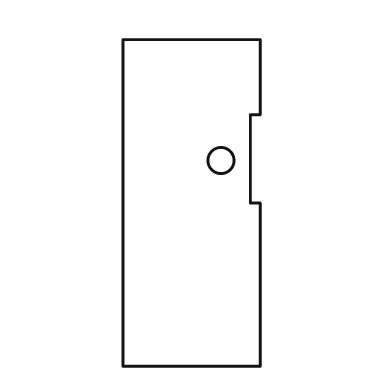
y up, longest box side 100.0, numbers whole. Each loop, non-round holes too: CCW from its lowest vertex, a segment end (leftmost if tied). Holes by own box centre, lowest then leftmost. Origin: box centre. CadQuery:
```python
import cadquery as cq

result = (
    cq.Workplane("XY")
    .moveTo(-21.0, -50.0)
    .lineTo(21.0, -50.0)
    .lineTo(21.0, 0.0)
    .lineTo(18.0, 0.0)
    .lineTo(18.0, 27.0)
    .lineTo(21.0, 27.0)
    .lineTo(21.0, 50.0)
    .lineTo(-21.0, 50.0)
    .close()
    .moveTo(9.0, 13.0)
    .circle(4.0)
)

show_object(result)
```